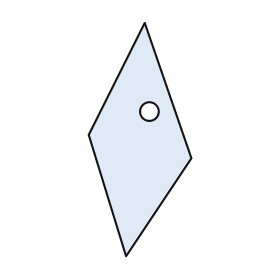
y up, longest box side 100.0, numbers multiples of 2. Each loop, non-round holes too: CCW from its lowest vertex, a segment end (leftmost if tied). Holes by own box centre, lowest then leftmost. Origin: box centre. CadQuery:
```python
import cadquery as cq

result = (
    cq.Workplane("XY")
    .moveTo(-6.0, -50.0)
    .lineTo(22.0, -8.0)
    .lineTo(2.0, 50.0)
    .lineTo(-22.0, 2.0)
    .close()
    .moveTo(4.0, 12.0)
    .circle(4.0)
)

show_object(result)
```